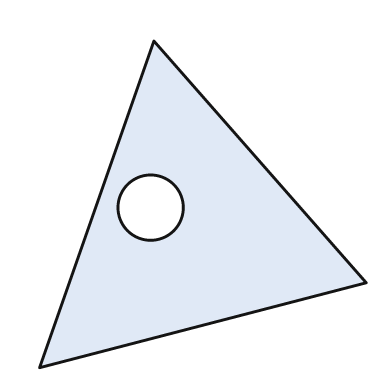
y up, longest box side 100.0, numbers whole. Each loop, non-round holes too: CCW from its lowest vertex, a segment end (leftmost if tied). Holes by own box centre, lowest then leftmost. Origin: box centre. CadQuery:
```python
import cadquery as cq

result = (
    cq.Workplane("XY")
    .moveTo(-50.0, -50.0)
    .lineTo(50.0, -24.0)
    .lineTo(-15.0, 50.0)
    .close()
    .moveTo(-16.0, -1.0)
    .circle(10.0)
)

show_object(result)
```